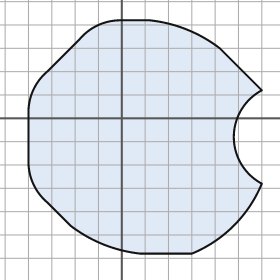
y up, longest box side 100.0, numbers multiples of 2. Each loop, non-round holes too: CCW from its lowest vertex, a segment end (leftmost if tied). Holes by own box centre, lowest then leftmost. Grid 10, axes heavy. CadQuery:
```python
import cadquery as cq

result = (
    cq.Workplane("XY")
    .moveTo(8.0, -58.0)
    .lineTo(30.0, -58.0)
    .threePointArc((48.0, -46.0), (60.0, -28.0))
    .threePointArc((48.0, -8.0), (60.0, 12.0))
    .lineTo(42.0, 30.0)
    .threePointArc((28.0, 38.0), (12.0, 42.0))
    .lineTo(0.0, 42.0)
    .threePointArc((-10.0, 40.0), (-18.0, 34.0))
    .lineTo(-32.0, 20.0)
    .threePointArc((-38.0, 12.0), (-40.0, 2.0))
    .lineTo(-40.0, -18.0)
    .threePointArc((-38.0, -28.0), (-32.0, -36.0))
    .lineTo(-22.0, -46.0)
    .threePointArc((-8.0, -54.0), (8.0, -58.0))
    .close()
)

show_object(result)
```